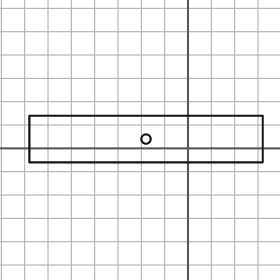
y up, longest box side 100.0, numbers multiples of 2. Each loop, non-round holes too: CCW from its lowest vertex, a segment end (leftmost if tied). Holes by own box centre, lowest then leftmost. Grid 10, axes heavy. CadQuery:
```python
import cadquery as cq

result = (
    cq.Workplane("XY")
    .moveTo(-68.0, -6.0)
    .lineTo(32.0, -6.0)
    .lineTo(32.0, 14.0)
    .lineTo(-68.0, 14.0)
    .close()
    .moveTo(-18.0, 4.0)
    .circle(2.0)
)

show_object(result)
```